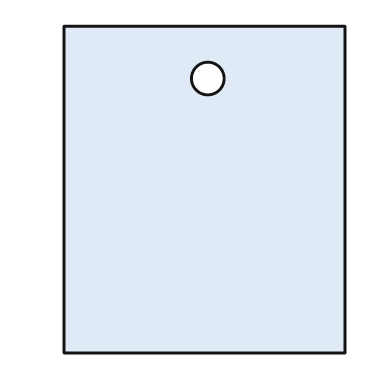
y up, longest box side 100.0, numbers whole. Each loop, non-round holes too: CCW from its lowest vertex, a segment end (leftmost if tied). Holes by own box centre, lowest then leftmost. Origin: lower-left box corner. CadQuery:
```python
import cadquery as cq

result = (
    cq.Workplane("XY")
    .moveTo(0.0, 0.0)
    .lineTo(86.0, 0.0)
    .lineTo(86.0, 100.0)
    .lineTo(0.0, 100.0)
    .close()
    .moveTo(44.0, 84.0)
    .circle(5.0)
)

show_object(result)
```